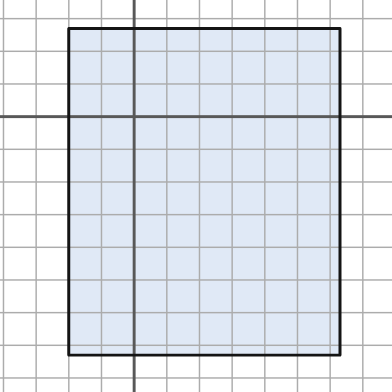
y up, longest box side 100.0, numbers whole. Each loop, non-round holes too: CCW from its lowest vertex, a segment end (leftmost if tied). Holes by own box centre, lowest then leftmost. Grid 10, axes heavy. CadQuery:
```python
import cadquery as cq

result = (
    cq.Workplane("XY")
    .moveTo(-20.0, -73.0)
    .lineTo(63.0, -73.0)
    .lineTo(63.0, 27.0)
    .lineTo(-20.0, 27.0)
    .close()
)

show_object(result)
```